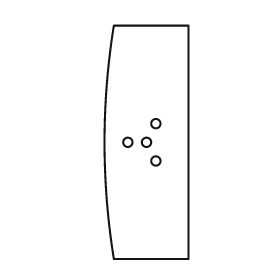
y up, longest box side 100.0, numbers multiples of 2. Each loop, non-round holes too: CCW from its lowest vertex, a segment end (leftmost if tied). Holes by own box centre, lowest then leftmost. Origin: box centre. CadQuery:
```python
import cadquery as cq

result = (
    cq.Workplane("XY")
    .moveTo(-14.0, -50.0)
    .lineTo(18.0, -50.0)
    .lineTo(18.0, 50.0)
    .lineTo(-14.0, 50.0)
    .threePointArc((-18.0, 0.0), (-14.0, -50.0))
    .close()
    .moveTo(4.0, -8.0)
    .circle(2.0)
    .moveTo(-8.0, 0.0)
    .circle(2.0)
    .moveTo(0.0, 0.0)
    .circle(2.0)
    .moveTo(4.0, 8.0)
    .circle(2.0)
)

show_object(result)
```